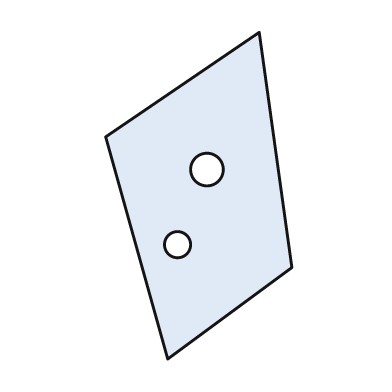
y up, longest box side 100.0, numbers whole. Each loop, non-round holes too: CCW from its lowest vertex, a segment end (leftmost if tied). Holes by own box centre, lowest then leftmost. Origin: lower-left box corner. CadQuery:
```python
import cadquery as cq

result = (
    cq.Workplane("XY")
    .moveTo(19.0, 0.0)
    .lineTo(57.0, 28.0)
    .lineTo(47.0, 100.0)
    .lineTo(0.0, 68.0)
    .close()
    .moveTo(22.0, 35.0)
    .circle(4.0)
    .moveTo(31.0, 58.0)
    .circle(5.0)
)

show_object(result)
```